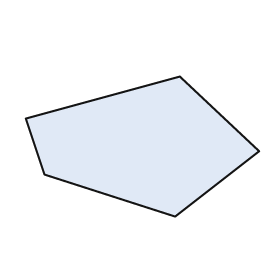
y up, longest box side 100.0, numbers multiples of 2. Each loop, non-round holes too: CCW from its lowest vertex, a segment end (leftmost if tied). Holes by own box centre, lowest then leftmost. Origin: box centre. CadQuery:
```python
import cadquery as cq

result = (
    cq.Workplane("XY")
    .moveTo(14.0, -30.0)
    .lineTo(50.0, -2.0)
    .lineTo(16.0, 30.0)
    .lineTo(-50.0, 12.0)
    .lineTo(-42.0, -12.0)
    .close()
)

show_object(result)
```